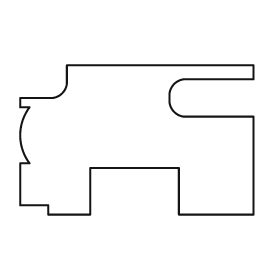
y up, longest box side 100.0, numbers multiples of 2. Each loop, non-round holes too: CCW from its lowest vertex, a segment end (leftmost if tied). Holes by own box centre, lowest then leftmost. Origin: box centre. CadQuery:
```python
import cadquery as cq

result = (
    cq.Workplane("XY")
    .moveTo(-38.0, -32.0)
    .lineTo(-20.0, -32.0)
    .lineTo(-20.0, -12.0)
    .lineTo(18.0, -12.0)
    .lineTo(18.0, -32.0)
    .lineTo(50.0, -32.0)
    .lineTo(50.0, 10.0)
    .lineTo(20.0, 10.0)
    .threePointArc((16.0, 12.0), (14.0, 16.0))
    .lineTo(14.0, 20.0)
    .threePointArc((16.0, 24.0), (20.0, 26.0))
    .lineTo(50.0, 26.0)
    .lineTo(50.0, 32.0)
    .lineTo(-30.0, 32.0)
    .lineTo(-30.0, 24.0)
    .threePointArc((-32.0, 20.0), (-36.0, 18.0))
    .lineTo(-50.0, 18.0)
    .lineTo(-50.0, 14.0)
    .lineTo(-46.0, 14.0)
    .threePointArc((-50.0, 2.0), (-46.0, -10.0))
    .lineTo(-50.0, -10.0)
    .lineTo(-50.0, -28.0)
    .lineTo(-38.0, -28.0)
    .close()
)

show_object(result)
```